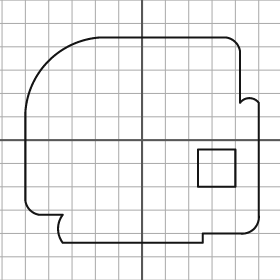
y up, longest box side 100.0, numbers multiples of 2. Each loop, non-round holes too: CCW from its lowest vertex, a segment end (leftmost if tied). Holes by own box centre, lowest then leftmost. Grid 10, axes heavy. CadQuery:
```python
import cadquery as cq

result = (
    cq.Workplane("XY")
    .moveTo(-34.0, -44.0)
    .lineTo(26.0, -44.0)
    .lineTo(26.0, -40.0)
    .lineTo(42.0, -40.0)
    .threePointArc((48.0, -38.0), (50.0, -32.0))
    .lineTo(50.0, 16.0)
    .threePointArc((46.0, 18.0), (42.0, 16.0))
    .lineTo(42.0, 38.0)
    .threePointArc((40.0, 42.0), (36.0, 44.0))
    .lineTo(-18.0, 44.0)
    .threePointArc((-40.0, 34.0), (-50.0, 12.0))
    .lineTo(-50.0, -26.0)
    .threePointArc((-48.0, -30.0), (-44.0, -32.0))
    .lineTo(-34.0, -32.0)
    .threePointArc((-36.0, -38.0), (-34.0, -44.0))
    .close()
    .moveTo(24.0, -20.0)
    .lineTo(40.0, -20.0)
    .lineTo(40.0, -4.0)
    .lineTo(24.0, -4.0)
    .close()
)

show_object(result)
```